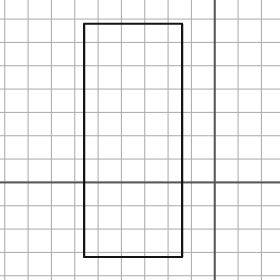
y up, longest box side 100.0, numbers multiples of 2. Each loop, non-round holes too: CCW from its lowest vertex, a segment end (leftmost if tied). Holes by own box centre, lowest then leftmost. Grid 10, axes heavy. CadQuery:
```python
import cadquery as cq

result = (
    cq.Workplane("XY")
    .moveTo(-56.0, -32.0)
    .lineTo(-14.0, -32.0)
    .lineTo(-14.0, 68.0)
    .lineTo(-56.0, 68.0)
    .close()
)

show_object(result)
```